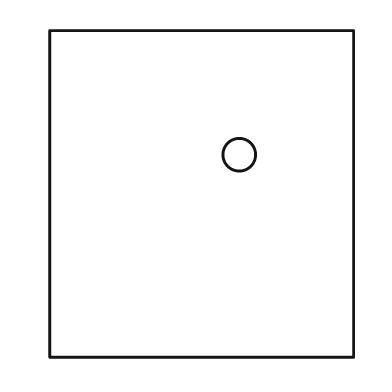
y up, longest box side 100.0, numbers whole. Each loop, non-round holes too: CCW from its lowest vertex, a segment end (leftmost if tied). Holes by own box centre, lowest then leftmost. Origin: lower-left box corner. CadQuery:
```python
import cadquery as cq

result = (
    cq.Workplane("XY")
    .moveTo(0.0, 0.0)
    .lineTo(93.0, 0.0)
    .lineTo(93.0, 100.0)
    .lineTo(0.0, 100.0)
    .close()
    .moveTo(58.0, 62.0)
    .circle(5.0)
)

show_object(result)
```